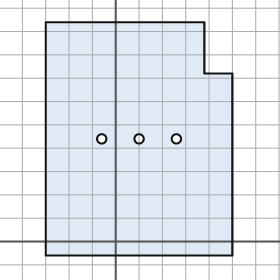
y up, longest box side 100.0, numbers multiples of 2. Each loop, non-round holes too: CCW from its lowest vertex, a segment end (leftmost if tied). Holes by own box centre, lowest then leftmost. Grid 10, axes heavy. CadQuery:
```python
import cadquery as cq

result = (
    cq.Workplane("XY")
    .moveTo(-30.0, -6.0)
    .lineTo(50.0, -6.0)
    .lineTo(50.0, 72.0)
    .lineTo(38.0, 72.0)
    .lineTo(38.0, 94.0)
    .lineTo(-30.0, 94.0)
    .close()
    .moveTo(-6.0, 44.0)
    .circle(2.0)
    .moveTo(10.0, 44.0)
    .circle(2.0)
    .moveTo(26.0, 44.0)
    .circle(2.0)
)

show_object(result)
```